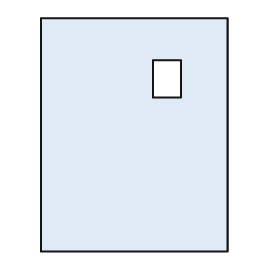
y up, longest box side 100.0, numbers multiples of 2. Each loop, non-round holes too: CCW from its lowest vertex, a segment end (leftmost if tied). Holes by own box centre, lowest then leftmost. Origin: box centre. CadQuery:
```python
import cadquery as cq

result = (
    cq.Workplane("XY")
    .moveTo(-40.0, -50.0)
    .lineTo(40.0, -50.0)
    .lineTo(40.0, 50.0)
    .lineTo(-40.0, 50.0)
    .close()
    .moveTo(8.0, 16.0)
    .lineTo(20.0, 16.0)
    .lineTo(20.0, 32.0)
    .lineTo(8.0, 32.0)
    .close()
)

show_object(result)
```